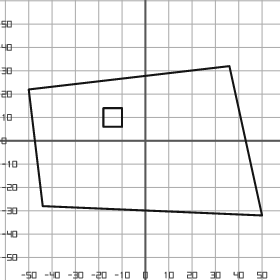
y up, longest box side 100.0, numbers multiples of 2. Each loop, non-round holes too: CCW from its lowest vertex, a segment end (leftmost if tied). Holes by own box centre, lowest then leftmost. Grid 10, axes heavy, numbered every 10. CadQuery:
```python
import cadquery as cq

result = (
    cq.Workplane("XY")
    .moveTo(50.0, -32.0)
    .lineTo(36.0, 32.0)
    .lineTo(-50.0, 22.0)
    .lineTo(-44.0, -28.0)
    .close()
    .moveTo(-18.0, 6.0)
    .lineTo(-10.0, 6.0)
    .lineTo(-10.0, 14.0)
    .lineTo(-18.0, 14.0)
    .close()
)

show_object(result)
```